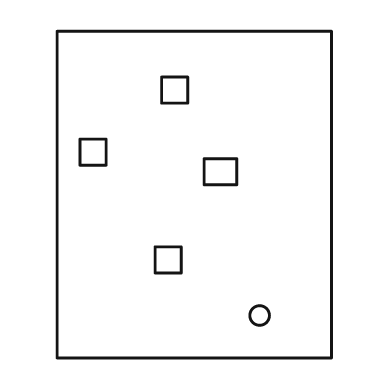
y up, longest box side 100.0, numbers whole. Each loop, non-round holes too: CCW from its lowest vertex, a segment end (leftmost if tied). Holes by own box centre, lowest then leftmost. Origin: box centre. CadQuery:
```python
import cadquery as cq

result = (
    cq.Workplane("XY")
    .moveTo(-42.0, -50.0)
    .lineTo(42.0, -50.0)
    .lineTo(42.0, 50.0)
    .lineTo(-42.0, 50.0)
    .close()
    .moveTo(20.0, -37.0)
    .circle(3.0)
    .moveTo(-12.0, -24.0)
    .lineTo(-4.0, -24.0)
    .lineTo(-4.0, -16.0)
    .lineTo(-12.0, -16.0)
    .close()
    .moveTo(3.0, 3.0)
    .lineTo(13.0, 3.0)
    .lineTo(13.0, 11.0)
    .lineTo(3.0, 11.0)
    .close()
    .moveTo(-35.0, 9.0)
    .lineTo(-27.0, 9.0)
    .lineTo(-27.0, 17.0)
    .lineTo(-35.0, 17.0)
    .close()
    .moveTo(-10.0, 28.0)
    .lineTo(-2.0, 28.0)
    .lineTo(-2.0, 36.0)
    .lineTo(-10.0, 36.0)
    .close()
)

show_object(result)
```